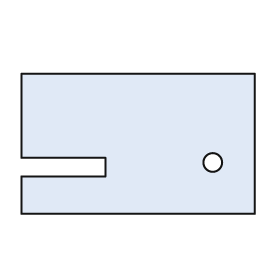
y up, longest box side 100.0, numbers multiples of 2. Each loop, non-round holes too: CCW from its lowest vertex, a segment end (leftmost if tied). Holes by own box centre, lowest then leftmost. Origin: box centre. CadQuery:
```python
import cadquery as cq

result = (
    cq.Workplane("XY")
    .moveTo(-50.0, -30.0)
    .lineTo(50.0, -30.0)
    .lineTo(50.0, 30.0)
    .lineTo(-50.0, 30.0)
    .lineTo(-50.0, -6.0)
    .lineTo(-14.0, -6.0)
    .lineTo(-14.0, -14.0)
    .lineTo(-50.0, -14.0)
    .close()
    .moveTo(32.0, -8.0)
    .circle(4.0)
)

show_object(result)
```